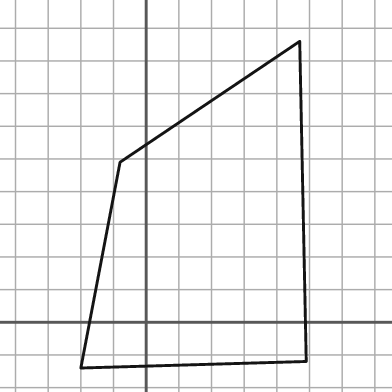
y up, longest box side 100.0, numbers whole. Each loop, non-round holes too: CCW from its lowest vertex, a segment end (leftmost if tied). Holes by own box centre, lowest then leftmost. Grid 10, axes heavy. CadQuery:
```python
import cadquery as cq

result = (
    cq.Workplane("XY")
    .moveTo(-20.0, -14.0)
    .lineTo(49.0, -12.0)
    .lineTo(47.0, 86.0)
    .lineTo(-8.0, 49.0)
    .close()
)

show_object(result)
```